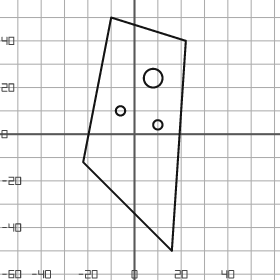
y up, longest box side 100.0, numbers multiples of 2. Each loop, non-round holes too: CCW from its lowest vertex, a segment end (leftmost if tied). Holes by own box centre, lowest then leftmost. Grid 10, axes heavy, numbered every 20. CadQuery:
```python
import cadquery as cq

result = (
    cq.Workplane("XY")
    .moveTo(16.0, -50.0)
    .lineTo(22.0, 40.0)
    .lineTo(-10.0, 50.0)
    .lineTo(-22.0, -12.0)
    .close()
    .moveTo(10.0, 4.0)
    .circle(2.0)
    .moveTo(-6.0, 10.0)
    .circle(2.0)
    .moveTo(8.0, 24.0)
    .circle(4.0)
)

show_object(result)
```